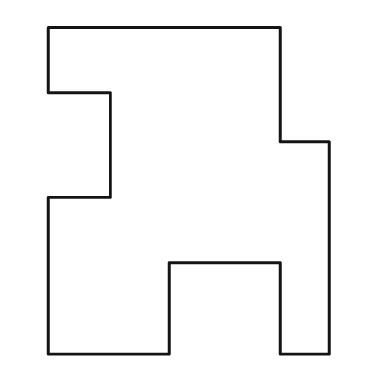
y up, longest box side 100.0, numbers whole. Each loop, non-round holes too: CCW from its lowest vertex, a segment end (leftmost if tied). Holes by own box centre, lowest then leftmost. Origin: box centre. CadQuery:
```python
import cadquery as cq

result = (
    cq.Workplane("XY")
    .moveTo(-43.0, -50.0)
    .lineTo(-6.0, -50.0)
    .lineTo(-6.0, -22.0)
    .lineTo(28.0, -22.0)
    .lineTo(28.0, -50.0)
    .lineTo(43.0, -50.0)
    .lineTo(43.0, 15.0)
    .lineTo(28.0, 15.0)
    .lineTo(28.0, 50.0)
    .lineTo(-43.0, 50.0)
    .lineTo(-43.0, 30.0)
    .lineTo(-24.0, 30.0)
    .lineTo(-24.0, -2.0)
    .lineTo(-43.0, -2.0)
    .close()
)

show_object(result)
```